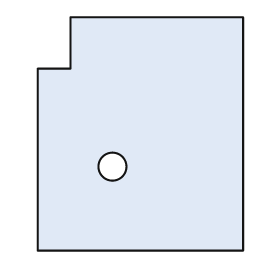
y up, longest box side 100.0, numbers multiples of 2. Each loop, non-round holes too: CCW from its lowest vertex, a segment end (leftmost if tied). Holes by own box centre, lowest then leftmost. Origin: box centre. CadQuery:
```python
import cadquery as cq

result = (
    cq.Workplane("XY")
    .moveTo(-44.0, -50.0)
    .lineTo(44.0, -50.0)
    .lineTo(44.0, 50.0)
    .lineTo(-30.0, 50.0)
    .lineTo(-30.0, 28.0)
    .lineTo(-44.0, 28.0)
    .close()
    .moveTo(-12.0, -14.0)
    .circle(6.0)
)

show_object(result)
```